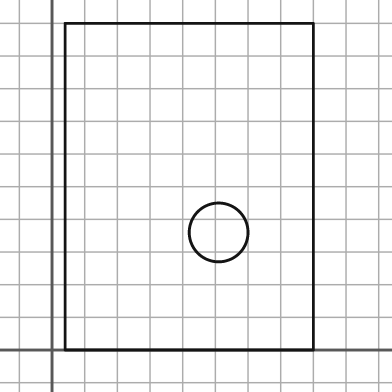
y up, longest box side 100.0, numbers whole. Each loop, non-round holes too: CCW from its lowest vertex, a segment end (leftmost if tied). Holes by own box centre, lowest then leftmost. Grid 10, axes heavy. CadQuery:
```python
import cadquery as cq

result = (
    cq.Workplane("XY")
    .moveTo(4.0, 0.0)
    .lineTo(80.0, 0.0)
    .lineTo(80.0, 100.0)
    .lineTo(4.0, 100.0)
    .close()
    .moveTo(51.0, 36.0)
    .circle(9.0)
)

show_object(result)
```